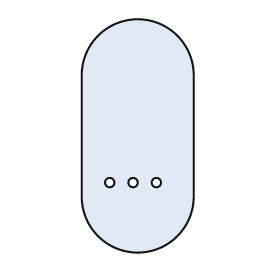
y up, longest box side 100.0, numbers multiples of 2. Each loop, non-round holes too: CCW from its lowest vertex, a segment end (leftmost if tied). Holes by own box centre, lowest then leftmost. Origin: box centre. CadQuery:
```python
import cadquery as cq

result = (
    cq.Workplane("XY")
    .moveTo(-24.0, -26.0)
    .threePointArc((0.0, -50.0), (24.0, -26.0))
    .lineTo(24.0, 26.0)
    .threePointArc((0.0, 50.0), (-24.0, 26.0))
    .close()
    .moveTo(-12.0, -20.0)
    .circle(2.0)
    .moveTo(-2.0, -20.0)
    .circle(2.0)
    .moveTo(8.0, -20.0)
    .circle(2.0)
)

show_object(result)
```